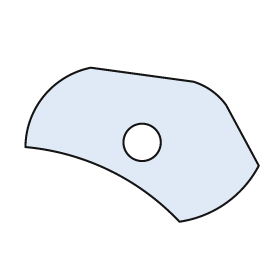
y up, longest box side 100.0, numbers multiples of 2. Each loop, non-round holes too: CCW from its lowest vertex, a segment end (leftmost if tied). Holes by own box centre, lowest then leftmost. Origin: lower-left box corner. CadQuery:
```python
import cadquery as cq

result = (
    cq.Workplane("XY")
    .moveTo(66.0, 0.0)
    .threePointArc((86.0, 8.0), (100.0, 24.0))
    .lineTo(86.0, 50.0)
    .threePointArc((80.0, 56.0), (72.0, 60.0))
    .lineTo(28.0, 66.0)
    .threePointArc((8.0, 54.0), (0.0, 32.0))
    .threePointArc((36.0, 22.0), (66.0, 0.0))
    .close()
    .moveTo(50.0, 34.0)
    .circle(8.0)
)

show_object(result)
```